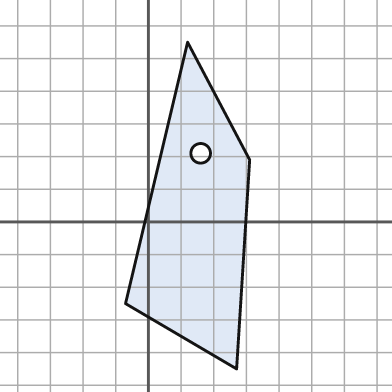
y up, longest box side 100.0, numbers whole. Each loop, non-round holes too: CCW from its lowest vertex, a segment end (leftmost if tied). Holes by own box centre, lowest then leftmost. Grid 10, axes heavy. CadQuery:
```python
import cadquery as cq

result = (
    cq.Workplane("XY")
    .moveTo(27.0, -45.0)
    .lineTo(31.0, 19.0)
    .lineTo(12.0, 55.0)
    .lineTo(-7.0, -25.0)
    .close()
    .moveTo(16.0, 21.0)
    .circle(3.0)
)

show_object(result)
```